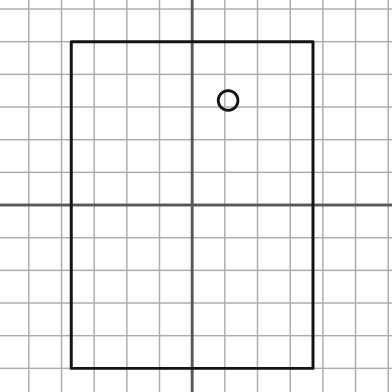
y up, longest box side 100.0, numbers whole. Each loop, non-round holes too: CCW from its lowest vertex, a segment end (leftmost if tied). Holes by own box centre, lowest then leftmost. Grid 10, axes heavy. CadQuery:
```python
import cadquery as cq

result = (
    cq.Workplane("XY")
    .moveTo(-37.0, -50.0)
    .lineTo(37.0, -50.0)
    .lineTo(37.0, 50.0)
    .lineTo(-37.0, 50.0)
    .close()
    .moveTo(11.0, 32.0)
    .circle(3.0)
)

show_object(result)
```